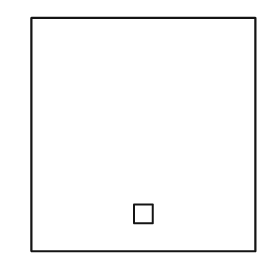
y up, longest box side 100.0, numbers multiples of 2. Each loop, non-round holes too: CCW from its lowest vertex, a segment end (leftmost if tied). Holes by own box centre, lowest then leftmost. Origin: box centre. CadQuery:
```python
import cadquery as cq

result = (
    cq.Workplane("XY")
    .moveTo(-48.0, -50.0)
    .lineTo(48.0, -50.0)
    .lineTo(48.0, 50.0)
    .lineTo(-48.0, 50.0)
    .close()
    .moveTo(-4.0, -38.0)
    .lineTo(4.0, -38.0)
    .lineTo(4.0, -30.0)
    .lineTo(-4.0, -30.0)
    .close()
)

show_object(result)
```